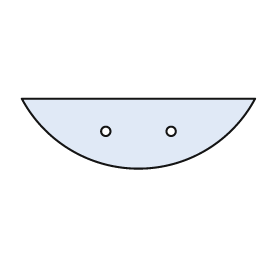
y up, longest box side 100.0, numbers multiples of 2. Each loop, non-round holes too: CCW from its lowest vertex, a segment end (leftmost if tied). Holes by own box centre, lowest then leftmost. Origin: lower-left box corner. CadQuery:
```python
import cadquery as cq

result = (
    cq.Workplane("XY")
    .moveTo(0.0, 30.0)
    .threePointArc((50.0, 0.0), (100.0, 30.0))
    .close()
    .moveTo(36.0, 16.0)
    .circle(2.0)
    .moveTo(64.0, 16.0)
    .circle(2.0)
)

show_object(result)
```